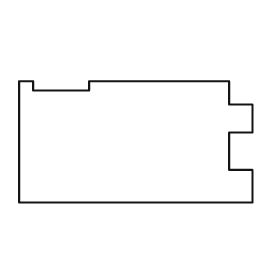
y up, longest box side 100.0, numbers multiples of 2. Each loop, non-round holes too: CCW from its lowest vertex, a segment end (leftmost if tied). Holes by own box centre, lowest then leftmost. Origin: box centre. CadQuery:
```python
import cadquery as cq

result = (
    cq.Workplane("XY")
    .moveTo(-50.0, -26.0)
    .lineTo(50.0, -26.0)
    .lineTo(50.0, -12.0)
    .lineTo(40.0, -12.0)
    .lineTo(40.0, 4.0)
    .lineTo(50.0, 4.0)
    .lineTo(50.0, 16.0)
    .lineTo(40.0, 16.0)
    .lineTo(40.0, 26.0)
    .lineTo(-20.0, 26.0)
    .lineTo(-20.0, 22.0)
    .lineTo(-44.0, 22.0)
    .lineTo(-44.0, 26.0)
    .lineTo(-50.0, 26.0)
    .close()
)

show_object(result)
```